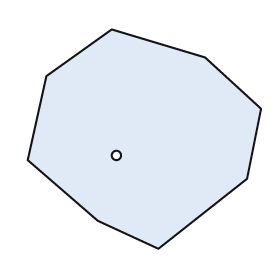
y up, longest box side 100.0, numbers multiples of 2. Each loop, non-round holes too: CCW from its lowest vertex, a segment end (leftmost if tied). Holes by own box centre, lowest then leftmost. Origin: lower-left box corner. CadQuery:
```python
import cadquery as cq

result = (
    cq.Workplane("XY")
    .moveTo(56.0, 0.0)
    .lineTo(94.0, 30.0)
    .lineTo(100.0, 60.0)
    .lineTo(76.0, 82.0)
    .lineTo(36.0, 94.0)
    .lineTo(8.0, 74.0)
    .lineTo(0.0, 38.0)
    .lineTo(30.0, 12.0)
    .close()
    .moveTo(38.0, 40.0)
    .circle(2.0)
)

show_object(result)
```